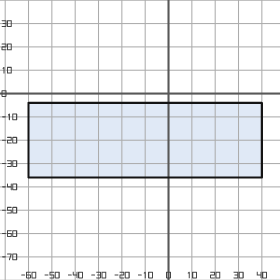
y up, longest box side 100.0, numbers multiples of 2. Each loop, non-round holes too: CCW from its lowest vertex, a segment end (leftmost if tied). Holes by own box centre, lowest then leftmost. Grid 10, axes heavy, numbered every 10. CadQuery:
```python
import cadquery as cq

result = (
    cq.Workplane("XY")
    .moveTo(-60.0, -36.0)
    .lineTo(40.0, -36.0)
    .lineTo(40.0, -4.0)
    .lineTo(-60.0, -4.0)
    .close()
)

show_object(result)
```